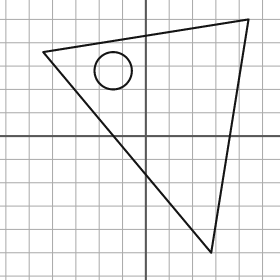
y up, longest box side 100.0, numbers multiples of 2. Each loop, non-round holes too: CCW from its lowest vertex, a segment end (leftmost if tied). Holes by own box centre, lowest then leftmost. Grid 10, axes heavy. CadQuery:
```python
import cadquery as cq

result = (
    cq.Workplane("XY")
    .moveTo(28.0, -50.0)
    .lineTo(44.0, 50.0)
    .lineTo(-44.0, 36.0)
    .close()
    .moveTo(-14.0, 28.0)
    .circle(8.0)
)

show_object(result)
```